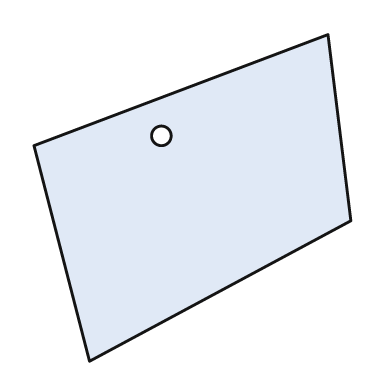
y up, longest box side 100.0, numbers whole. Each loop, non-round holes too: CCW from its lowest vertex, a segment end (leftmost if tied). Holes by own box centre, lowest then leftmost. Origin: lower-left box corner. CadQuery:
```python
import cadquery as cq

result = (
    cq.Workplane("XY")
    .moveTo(17.0, 0.0)
    .lineTo(97.0, 43.0)
    .lineTo(90.0, 100.0)
    .lineTo(0.0, 66.0)
    .close()
    .moveTo(39.0, 69.0)
    .circle(3.0)
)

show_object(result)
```